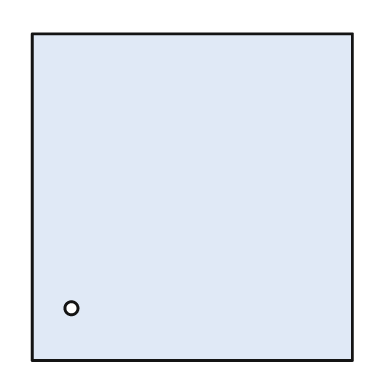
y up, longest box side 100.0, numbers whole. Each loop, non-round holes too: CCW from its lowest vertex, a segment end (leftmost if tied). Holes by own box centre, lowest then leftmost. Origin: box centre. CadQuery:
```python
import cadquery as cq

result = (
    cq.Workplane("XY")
    .moveTo(-49.0, -50.0)
    .lineTo(49.0, -50.0)
    .lineTo(49.0, 50.0)
    .lineTo(-49.0, 50.0)
    .close()
    .moveTo(-37.0, -34.0)
    .circle(2.0)
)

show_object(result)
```